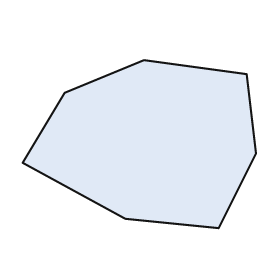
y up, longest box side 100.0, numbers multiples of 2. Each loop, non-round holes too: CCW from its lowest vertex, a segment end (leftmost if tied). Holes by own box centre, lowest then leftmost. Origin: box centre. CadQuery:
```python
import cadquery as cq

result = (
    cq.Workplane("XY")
    .moveTo(34.0, -36.0)
    .lineTo(50.0, -4.0)
    .lineTo(46.0, 30.0)
    .lineTo(2.0, 36.0)
    .lineTo(-32.0, 22.0)
    .lineTo(-50.0, -8.0)
    .lineTo(-6.0, -32.0)
    .close()
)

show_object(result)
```